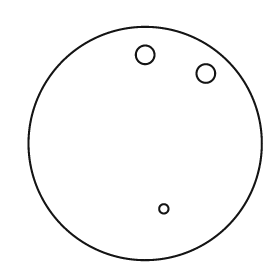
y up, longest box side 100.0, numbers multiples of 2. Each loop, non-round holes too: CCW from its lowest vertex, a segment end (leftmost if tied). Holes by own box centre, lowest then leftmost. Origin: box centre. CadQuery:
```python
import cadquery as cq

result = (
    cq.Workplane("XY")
    .moveTo(0.0, 0.0)
    .circle(50.0)
    .moveTo(8.0, -28.0)
    .circle(2.0)
    .moveTo(26.0, 30.0)
    .circle(4.0)
    .moveTo(0.0, 38.0)
    .circle(4.0)
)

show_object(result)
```